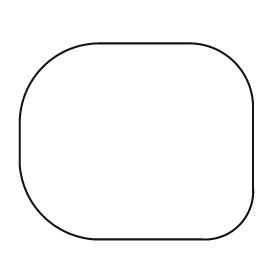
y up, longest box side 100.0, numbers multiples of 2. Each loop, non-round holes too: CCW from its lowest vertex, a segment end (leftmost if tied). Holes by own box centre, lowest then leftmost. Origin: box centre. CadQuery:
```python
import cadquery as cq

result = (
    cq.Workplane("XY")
    .moveTo(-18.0, -42.0)
    .lineTo(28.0, -42.0)
    .threePointArc((44.0, -36.0), (50.0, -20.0))
    .lineTo(50.0, 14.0)
    .threePointArc((42.0, 34.0), (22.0, 42.0))
    .lineTo(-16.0, 42.0)
    .threePointArc((-40.0, 32.0), (-50.0, 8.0))
    .lineTo(-50.0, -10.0)
    .threePointArc((-40.0, -32.0), (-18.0, -42.0))
    .close()
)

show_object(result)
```